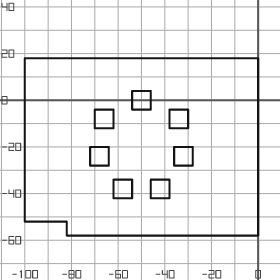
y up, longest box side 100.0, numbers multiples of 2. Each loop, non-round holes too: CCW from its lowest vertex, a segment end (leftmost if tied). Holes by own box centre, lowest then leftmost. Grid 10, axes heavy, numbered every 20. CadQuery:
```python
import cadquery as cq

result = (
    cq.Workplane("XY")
    .moveTo(-82.0, -58.0)
    .lineTo(0.0, -58.0)
    .lineTo(0.0, 18.0)
    .lineTo(-100.0, 18.0)
    .lineTo(-100.0, -52.0)
    .lineTo(-82.0, -52.0)
    .close()
    .moveTo(-62.0, -42.0)
    .lineTo(-54.0, -42.0)
    .lineTo(-54.0, -34.0)
    .lineTo(-62.0, -34.0)
    .close()
    .moveTo(-46.0, -42.0)
    .lineTo(-38.0, -42.0)
    .lineTo(-38.0, -34.0)
    .lineTo(-46.0, -34.0)
    .close()
    .moveTo(-72.0, -28.0)
    .lineTo(-64.0, -28.0)
    .lineTo(-64.0, -20.0)
    .lineTo(-72.0, -20.0)
    .close()
    .moveTo(-36.0, -28.0)
    .lineTo(-28.0, -28.0)
    .lineTo(-28.0, -20.0)
    .lineTo(-36.0, -20.0)
    .close()
    .moveTo(-70.0, -12.0)
    .lineTo(-62.0, -12.0)
    .lineTo(-62.0, -4.0)
    .lineTo(-70.0, -4.0)
    .close()
    .moveTo(-38.0, -12.0)
    .lineTo(-30.0, -12.0)
    .lineTo(-30.0, -4.0)
    .lineTo(-38.0, -4.0)
    .close()
    .moveTo(-54.0, -4.0)
    .lineTo(-46.0, -4.0)
    .lineTo(-46.0, 4.0)
    .lineTo(-54.0, 4.0)
    .close()
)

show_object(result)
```